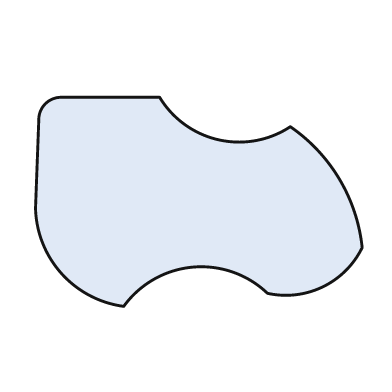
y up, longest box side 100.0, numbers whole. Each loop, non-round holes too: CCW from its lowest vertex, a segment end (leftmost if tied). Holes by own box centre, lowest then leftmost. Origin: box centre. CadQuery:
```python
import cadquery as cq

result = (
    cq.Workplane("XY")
    .moveTo(-23.0, -32.0)
    .threePointArc((-2.0, -20.0), (21.0, -28.0))
    .threePointArc((38.0, -26.0), (50.0, -14.0))
    .threePointArc((43.0, 7.0), (28.0, 23.0))
    .threePointArc((6.0, 19.0), (-12.0, 32.0))
    .lineTo(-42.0, 32.0)
    .threePointArc((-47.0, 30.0), (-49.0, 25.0))
    .lineTo(-50.0, -2.0)
    .threePointArc((-42.0, -22.0), (-23.0, -32.0))
    .close()
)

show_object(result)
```